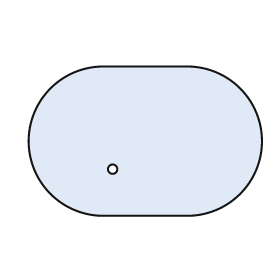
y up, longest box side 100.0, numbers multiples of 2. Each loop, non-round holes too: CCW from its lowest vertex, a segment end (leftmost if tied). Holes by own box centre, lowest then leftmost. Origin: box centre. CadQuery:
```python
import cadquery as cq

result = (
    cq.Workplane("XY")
    .moveTo(-18.0, -32.0)
    .lineTo(18.0, -32.0)
    .threePointArc((50.0, 0.0), (18.0, 32.0))
    .lineTo(-18.0, 32.0)
    .threePointArc((-50.0, 0.0), (-18.0, -32.0))
    .close()
    .moveTo(-14.0, -12.0)
    .circle(2.0)
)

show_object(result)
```